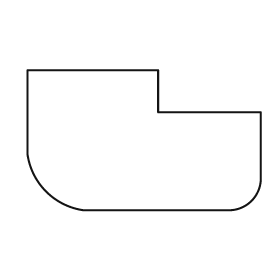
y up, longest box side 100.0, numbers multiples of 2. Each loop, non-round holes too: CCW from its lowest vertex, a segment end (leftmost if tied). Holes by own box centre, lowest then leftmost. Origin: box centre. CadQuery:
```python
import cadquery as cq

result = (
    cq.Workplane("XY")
    .moveTo(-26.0, -30.0)
    .lineTo(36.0, -30.0)
    .threePointArc((46.0, -26.0), (50.0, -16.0))
    .lineTo(50.0, 12.0)
    .lineTo(6.0, 12.0)
    .lineTo(6.0, 30.0)
    .lineTo(-50.0, 30.0)
    .lineTo(-50.0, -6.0)
    .threePointArc((-42.0, -22.0), (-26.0, -30.0))
    .close()
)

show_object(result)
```